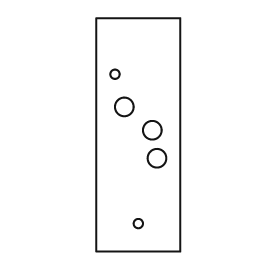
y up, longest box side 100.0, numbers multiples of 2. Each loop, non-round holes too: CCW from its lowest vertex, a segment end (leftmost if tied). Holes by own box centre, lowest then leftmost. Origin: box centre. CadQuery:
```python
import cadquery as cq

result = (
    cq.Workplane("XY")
    .moveTo(-18.0, -50.0)
    .lineTo(18.0, -50.0)
    .lineTo(18.0, 50.0)
    .lineTo(-18.0, 50.0)
    .close()
    .moveTo(0.0, -38.0)
    .circle(2.0)
    .moveTo(8.0, -10.0)
    .circle(4.0)
    .moveTo(6.0, 2.0)
    .circle(4.0)
    .moveTo(-6.0, 12.0)
    .circle(4.0)
    .moveTo(-10.0, 26.0)
    .circle(2.0)
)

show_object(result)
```